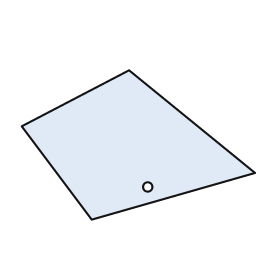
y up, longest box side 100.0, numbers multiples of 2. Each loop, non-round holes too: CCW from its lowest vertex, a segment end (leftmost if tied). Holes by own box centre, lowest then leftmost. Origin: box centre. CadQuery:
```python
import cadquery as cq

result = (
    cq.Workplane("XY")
    .moveTo(-20.0, -32.0)
    .lineTo(50.0, -12.0)
    .lineTo(-4.0, 32.0)
    .lineTo(-50.0, 8.0)
    .close()
    .moveTo(4.0, -18.0)
    .circle(2.0)
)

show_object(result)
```